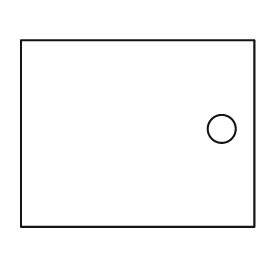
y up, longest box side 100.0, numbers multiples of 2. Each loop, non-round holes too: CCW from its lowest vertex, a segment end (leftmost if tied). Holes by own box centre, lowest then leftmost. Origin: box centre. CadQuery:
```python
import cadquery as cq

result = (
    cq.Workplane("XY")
    .moveTo(-50.0, -40.0)
    .lineTo(50.0, -40.0)
    .lineTo(50.0, 40.0)
    .lineTo(-50.0, 40.0)
    .close()
    .moveTo(36.0, 2.0)
    .circle(6.0)
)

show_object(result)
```